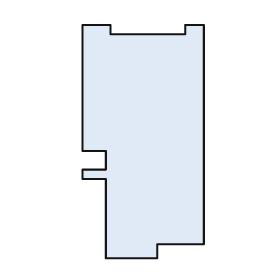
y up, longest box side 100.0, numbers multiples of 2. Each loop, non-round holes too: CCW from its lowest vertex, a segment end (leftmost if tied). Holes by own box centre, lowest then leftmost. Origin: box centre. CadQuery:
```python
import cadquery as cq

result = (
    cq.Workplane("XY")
    .moveTo(-16.0, -50.0)
    .lineTo(6.0, -50.0)
    .lineTo(6.0, -44.0)
    .lineTo(26.0, -44.0)
    .lineTo(26.0, 50.0)
    .lineTo(18.0, 50.0)
    .lineTo(18.0, 46.0)
    .lineTo(-14.0, 46.0)
    .lineTo(-14.0, 50.0)
    .lineTo(-26.0, 50.0)
    .lineTo(-26.0, -4.0)
    .lineTo(-16.0, -4.0)
    .lineTo(-16.0, -12.0)
    .lineTo(-26.0, -12.0)
    .lineTo(-26.0, -16.0)
    .lineTo(-16.0, -16.0)
    .close()
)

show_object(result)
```